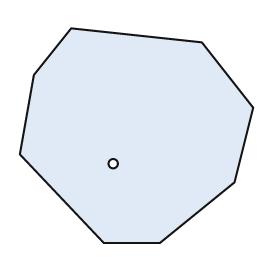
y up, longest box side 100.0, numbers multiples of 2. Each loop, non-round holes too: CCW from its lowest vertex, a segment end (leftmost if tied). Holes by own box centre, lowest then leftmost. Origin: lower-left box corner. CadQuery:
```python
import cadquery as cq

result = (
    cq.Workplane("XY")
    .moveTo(36.0, 0.0)
    .lineTo(60.0, 0.0)
    .lineTo(92.0, 26.0)
    .lineTo(100.0, 58.0)
    .lineTo(78.0, 86.0)
    .lineTo(22.0, 92.0)
    .lineTo(6.0, 72.0)
    .lineTo(0.0, 38.0)
    .close()
    .moveTo(40.0, 34.0)
    .circle(2.0)
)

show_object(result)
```